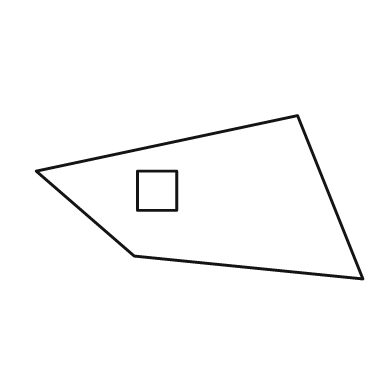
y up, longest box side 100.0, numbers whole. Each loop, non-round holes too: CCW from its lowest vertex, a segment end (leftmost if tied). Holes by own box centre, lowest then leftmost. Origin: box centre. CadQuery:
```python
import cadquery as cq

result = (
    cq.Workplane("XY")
    .moveTo(50.0, -25.0)
    .lineTo(30.0, 25.0)
    .lineTo(-50.0, 8.0)
    .lineTo(-20.0, -18.0)
    .close()
    .moveTo(-19.0, -4.0)
    .lineTo(-7.0, -4.0)
    .lineTo(-7.0, 8.0)
    .lineTo(-19.0, 8.0)
    .close()
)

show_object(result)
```